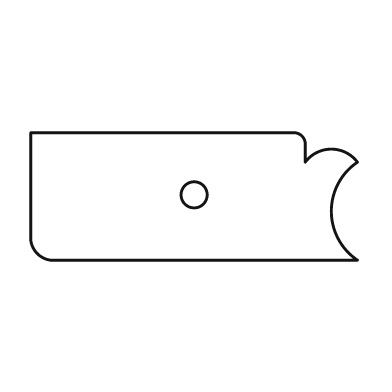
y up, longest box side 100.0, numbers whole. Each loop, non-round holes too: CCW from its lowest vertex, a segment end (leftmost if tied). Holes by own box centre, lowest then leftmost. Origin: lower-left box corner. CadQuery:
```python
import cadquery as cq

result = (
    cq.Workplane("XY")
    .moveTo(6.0, 0.0)
    .lineTo(100.0, 0.0)
    .threePointArc((92.0, 15.0), (100.0, 30.0))
    .threePointArc((92.0, 34.0), (84.0, 30.0))
    .lineTo(84.0, 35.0)
    .threePointArc((83.0, 38.0), (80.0, 39.0))
    .lineTo(0.0, 39.0)
    .lineTo(0.0, 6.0)
    .threePointArc((2.0, 2.0), (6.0, 0.0))
    .close()
    .moveTo(50.0, 20.0)
    .circle(4.0)
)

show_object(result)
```